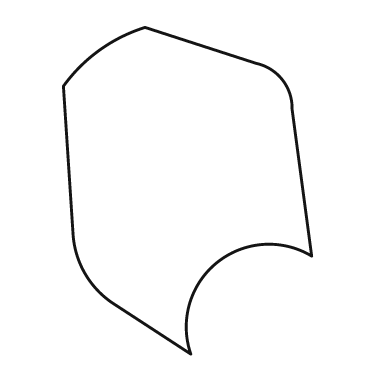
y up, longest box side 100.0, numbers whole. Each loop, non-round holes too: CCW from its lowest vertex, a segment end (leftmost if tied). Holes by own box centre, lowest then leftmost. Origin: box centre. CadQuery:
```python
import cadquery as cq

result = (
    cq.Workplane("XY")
    .moveTo(1.0, -50.0)
    .threePointArc((9.0, -22.0), (38.0, -20.0))
    .lineTo(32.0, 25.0)
    .threePointArc((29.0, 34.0), (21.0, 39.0))
    .lineTo(-13.0, 50.0)
    .threePointArc((-27.0, 43.0), (-38.0, 32.0))
    .lineTo(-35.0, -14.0)
    .threePointArc((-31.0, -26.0), (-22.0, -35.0))
    .close()
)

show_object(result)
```